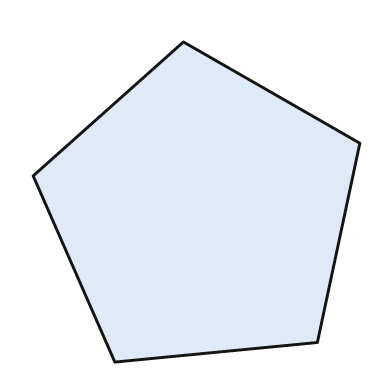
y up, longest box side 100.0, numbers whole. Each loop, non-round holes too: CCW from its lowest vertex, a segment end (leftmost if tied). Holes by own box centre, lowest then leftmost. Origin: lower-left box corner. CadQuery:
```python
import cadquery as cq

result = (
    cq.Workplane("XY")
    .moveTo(25.0, 0.0)
    .lineTo(87.0, 6.0)
    .lineTo(100.0, 67.0)
    .lineTo(46.0, 98.0)
    .lineTo(0.0, 57.0)
    .close()
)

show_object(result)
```